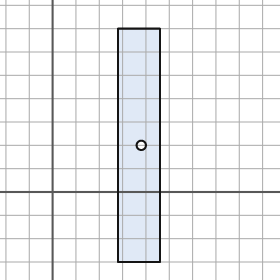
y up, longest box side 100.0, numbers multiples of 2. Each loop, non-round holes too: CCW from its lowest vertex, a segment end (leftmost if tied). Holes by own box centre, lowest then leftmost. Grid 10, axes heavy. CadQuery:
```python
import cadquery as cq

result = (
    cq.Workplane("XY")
    .moveTo(28.0, -30.0)
    .lineTo(46.0, -30.0)
    .lineTo(46.0, 70.0)
    .lineTo(28.0, 70.0)
    .close()
    .moveTo(38.0, 20.0)
    .circle(2.0)
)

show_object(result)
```